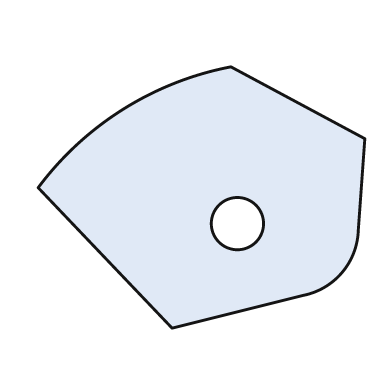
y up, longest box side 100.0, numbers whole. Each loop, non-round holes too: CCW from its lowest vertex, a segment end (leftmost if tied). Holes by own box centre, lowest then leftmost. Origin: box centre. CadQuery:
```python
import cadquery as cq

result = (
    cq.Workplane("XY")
    .moveTo(-9.0, -40.0)
    .lineTo(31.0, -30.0)
    .threePointArc((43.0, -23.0), (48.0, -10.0))
    .lineTo(50.0, 18.0)
    .lineTo(9.0, 40.0)
    .threePointArc((-24.0, 27.0), (-50.0, 3.0))
    .close()
    .moveTo(11.0, -8.0)
    .circle(8.0)
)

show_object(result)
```